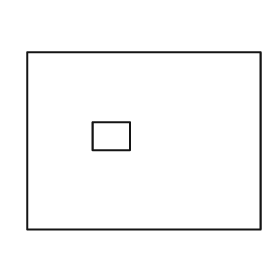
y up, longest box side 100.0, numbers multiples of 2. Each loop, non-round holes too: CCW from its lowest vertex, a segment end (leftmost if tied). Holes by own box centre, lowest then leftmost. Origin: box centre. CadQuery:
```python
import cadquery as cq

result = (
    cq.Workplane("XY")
    .moveTo(-50.0, -38.0)
    .lineTo(50.0, -38.0)
    .lineTo(50.0, 38.0)
    .lineTo(-50.0, 38.0)
    .close()
    .moveTo(-22.0, -4.0)
    .lineTo(-6.0, -4.0)
    .lineTo(-6.0, 8.0)
    .lineTo(-22.0, 8.0)
    .close()
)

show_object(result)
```